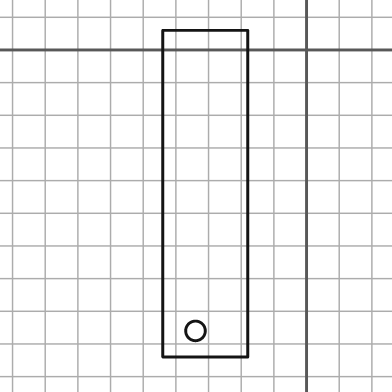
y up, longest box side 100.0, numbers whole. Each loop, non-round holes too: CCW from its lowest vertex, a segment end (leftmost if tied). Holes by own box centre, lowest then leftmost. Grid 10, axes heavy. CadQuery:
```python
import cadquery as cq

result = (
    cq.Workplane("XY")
    .moveTo(-44.0, -94.0)
    .lineTo(-18.0, -94.0)
    .lineTo(-18.0, 6.0)
    .lineTo(-44.0, 6.0)
    .close()
    .moveTo(-34.0, -86.0)
    .circle(3.0)
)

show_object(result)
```